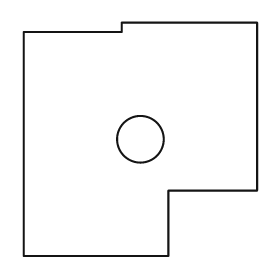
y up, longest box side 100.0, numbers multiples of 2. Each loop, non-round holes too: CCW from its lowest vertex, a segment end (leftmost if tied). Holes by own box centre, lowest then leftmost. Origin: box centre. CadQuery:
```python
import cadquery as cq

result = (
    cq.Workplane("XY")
    .moveTo(-50.0, -50.0)
    .lineTo(12.0, -50.0)
    .lineTo(12.0, -22.0)
    .lineTo(50.0, -22.0)
    .lineTo(50.0, 50.0)
    .lineTo(-8.0, 50.0)
    .lineTo(-8.0, 46.0)
    .lineTo(-50.0, 46.0)
    .close()
    .moveTo(0.0, 0.0)
    .circle(10.0)
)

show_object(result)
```